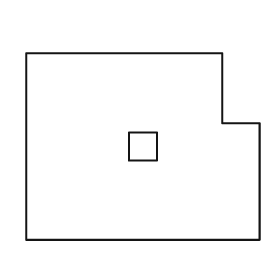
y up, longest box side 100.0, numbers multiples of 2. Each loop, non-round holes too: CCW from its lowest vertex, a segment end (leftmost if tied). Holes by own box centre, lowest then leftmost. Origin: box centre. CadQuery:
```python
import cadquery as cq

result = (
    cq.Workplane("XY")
    .moveTo(-50.0, -40.0)
    .lineTo(50.0, -40.0)
    .lineTo(50.0, 10.0)
    .lineTo(34.0, 10.0)
    .lineTo(34.0, 40.0)
    .lineTo(-50.0, 40.0)
    .close()
    .moveTo(-6.0, -6.0)
    .lineTo(6.0, -6.0)
    .lineTo(6.0, 6.0)
    .lineTo(-6.0, 6.0)
    .close()
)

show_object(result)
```